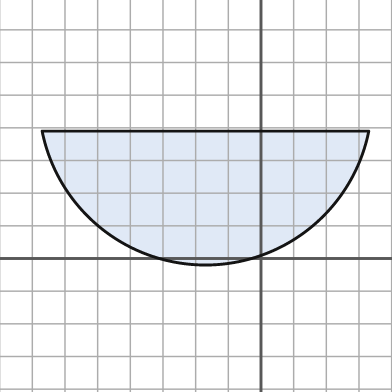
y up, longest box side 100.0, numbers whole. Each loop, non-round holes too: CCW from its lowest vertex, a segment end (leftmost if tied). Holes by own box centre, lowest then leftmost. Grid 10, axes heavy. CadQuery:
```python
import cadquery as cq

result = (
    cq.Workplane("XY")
    .moveTo(-67.0, 39.0)
    .threePointArc((-17.0, -2.0), (33.0, 39.0))
    .close()
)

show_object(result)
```